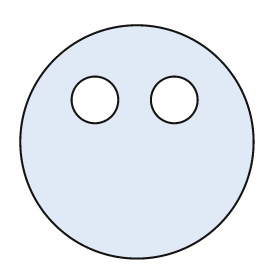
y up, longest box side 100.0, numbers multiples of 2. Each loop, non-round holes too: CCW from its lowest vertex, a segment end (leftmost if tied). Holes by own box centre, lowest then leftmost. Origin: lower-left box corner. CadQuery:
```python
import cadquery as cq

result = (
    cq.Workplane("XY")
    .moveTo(50.0, 50.0)
    .circle(50.0)
    .moveTo(32.0, 68.0)
    .circle(10.0)
    .moveTo(66.0, 68.0)
    .circle(10.0)
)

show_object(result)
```